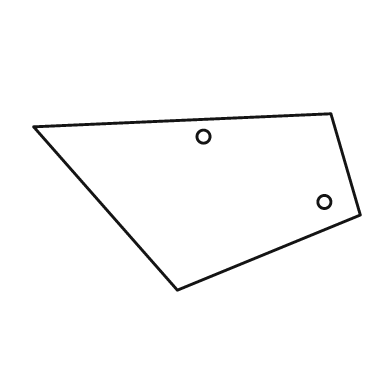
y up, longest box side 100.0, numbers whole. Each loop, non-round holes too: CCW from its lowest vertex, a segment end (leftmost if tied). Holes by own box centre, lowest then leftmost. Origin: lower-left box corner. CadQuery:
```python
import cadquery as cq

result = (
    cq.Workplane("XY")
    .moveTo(44.0, 0.0)
    .lineTo(100.0, 23.0)
    .lineTo(91.0, 54.0)
    .lineTo(0.0, 50.0)
    .close()
    .moveTo(89.0, 27.0)
    .circle(2.0)
    .moveTo(52.0, 47.0)
    .circle(2.0)
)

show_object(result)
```